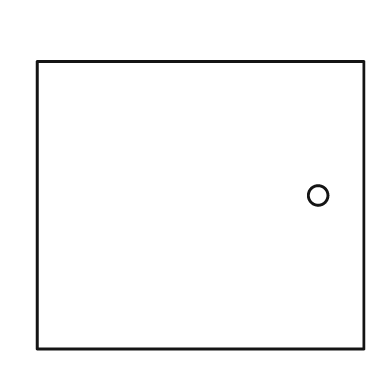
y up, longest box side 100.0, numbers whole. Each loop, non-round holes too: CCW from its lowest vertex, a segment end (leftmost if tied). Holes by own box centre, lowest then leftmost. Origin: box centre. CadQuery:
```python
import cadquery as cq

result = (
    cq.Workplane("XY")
    .moveTo(-50.0, -44.0)
    .lineTo(50.0, -44.0)
    .lineTo(50.0, 44.0)
    .lineTo(-50.0, 44.0)
    .close()
    .moveTo(36.0, 3.0)
    .circle(3.0)
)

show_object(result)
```